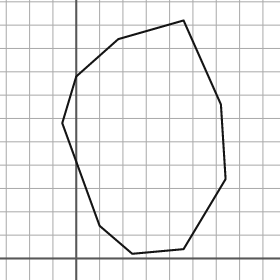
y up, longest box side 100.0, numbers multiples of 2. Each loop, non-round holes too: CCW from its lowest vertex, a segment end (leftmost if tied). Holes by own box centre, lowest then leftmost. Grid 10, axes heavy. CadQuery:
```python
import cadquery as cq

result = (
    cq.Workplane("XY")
    .moveTo(24.0, 2.0)
    .lineTo(46.0, 4.0)
    .lineTo(64.0, 34.0)
    .lineTo(62.0, 66.0)
    .lineTo(46.0, 102.0)
    .lineTo(18.0, 94.0)
    .lineTo(0.0, 78.0)
    .lineTo(-6.0, 58.0)
    .lineTo(10.0, 14.0)
    .close()
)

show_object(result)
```